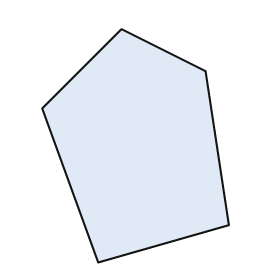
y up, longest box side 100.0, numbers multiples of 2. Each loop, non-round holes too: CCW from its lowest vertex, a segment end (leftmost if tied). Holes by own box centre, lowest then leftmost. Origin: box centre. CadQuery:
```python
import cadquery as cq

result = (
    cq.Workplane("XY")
    .moveTo(-16.0, -50.0)
    .lineTo(40.0, -34.0)
    .lineTo(30.0, 32.0)
    .lineTo(-6.0, 50.0)
    .lineTo(-40.0, 16.0)
    .close()
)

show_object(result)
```